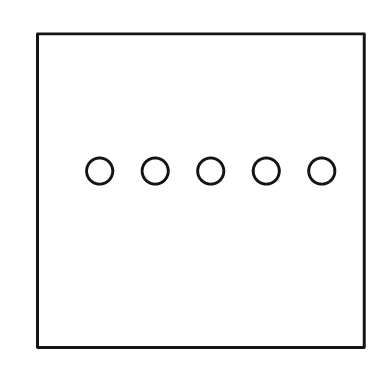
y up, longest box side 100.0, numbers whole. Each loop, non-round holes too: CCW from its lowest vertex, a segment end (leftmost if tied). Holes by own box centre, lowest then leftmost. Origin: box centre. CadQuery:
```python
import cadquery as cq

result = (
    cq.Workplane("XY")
    .moveTo(-50.0, -48.0)
    .lineTo(50.0, -48.0)
    .lineTo(50.0, 48.0)
    .lineTo(-50.0, 48.0)
    .close()
    .moveTo(-31.0, 6.0)
    .circle(4.0)
    .moveTo(-14.0, 6.0)
    .circle(4.0)
    .moveTo(3.0, 6.0)
    .circle(4.0)
    .moveTo(20.0, 6.0)
    .circle(4.0)
    .moveTo(37.0, 6.0)
    .circle(4.0)
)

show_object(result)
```